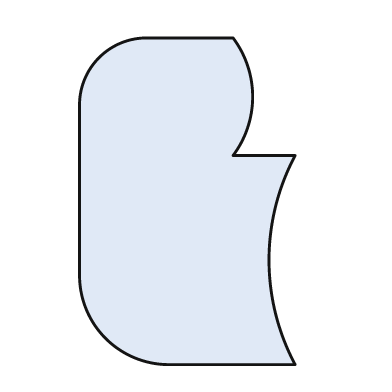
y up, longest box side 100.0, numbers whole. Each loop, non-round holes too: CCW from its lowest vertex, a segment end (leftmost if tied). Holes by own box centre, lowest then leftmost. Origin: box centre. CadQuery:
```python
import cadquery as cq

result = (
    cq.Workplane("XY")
    .moveTo(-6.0, -50.0)
    .lineTo(33.0, -50.0)
    .threePointArc((25.0, -18.0), (33.0, 14.0))
    .lineTo(14.0, 14.0)
    .threePointArc((20.0, 32.0), (14.0, 50.0))
    .lineTo(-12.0, 50.0)
    .threePointArc((-27.0, 44.0), (-33.0, 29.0))
    .lineTo(-33.0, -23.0)
    .threePointArc((-25.0, -42.0), (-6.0, -50.0))
    .close()
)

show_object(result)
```